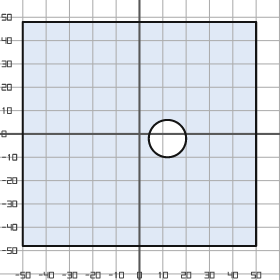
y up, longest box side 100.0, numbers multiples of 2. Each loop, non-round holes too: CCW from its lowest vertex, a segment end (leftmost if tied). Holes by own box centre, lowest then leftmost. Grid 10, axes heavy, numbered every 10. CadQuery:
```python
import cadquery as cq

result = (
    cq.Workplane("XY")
    .moveTo(-50.0, -48.0)
    .lineTo(50.0, -48.0)
    .lineTo(50.0, 48.0)
    .lineTo(-50.0, 48.0)
    .close()
    .moveTo(12.0, -2.0)
    .circle(8.0)
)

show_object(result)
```